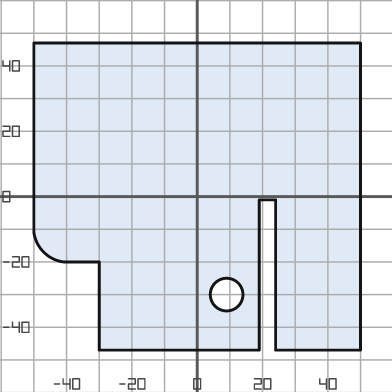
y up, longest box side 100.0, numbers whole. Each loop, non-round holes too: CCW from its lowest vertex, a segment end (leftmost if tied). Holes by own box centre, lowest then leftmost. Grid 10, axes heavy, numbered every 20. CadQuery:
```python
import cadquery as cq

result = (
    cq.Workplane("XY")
    .moveTo(-30.0, -47.0)
    .lineTo(19.0, -47.0)
    .lineTo(19.0, -1.0)
    .lineTo(24.0, -1.0)
    .lineTo(24.0, -47.0)
    .lineTo(50.0, -47.0)
    .lineTo(50.0, 47.0)
    .lineTo(-50.0, 47.0)
    .lineTo(-50.0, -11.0)
    .threePointArc((-47.0, -17.0), (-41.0, -20.0))
    .lineTo(-30.0, -20.0)
    .close()
    .moveTo(9.0, -30.0)
    .circle(5.0)
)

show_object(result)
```